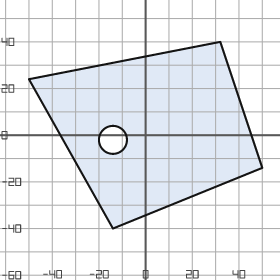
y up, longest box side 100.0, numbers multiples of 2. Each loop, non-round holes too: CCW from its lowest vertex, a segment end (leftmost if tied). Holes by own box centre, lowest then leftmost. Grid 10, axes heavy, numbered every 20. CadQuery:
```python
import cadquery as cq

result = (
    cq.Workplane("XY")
    .moveTo(-14.0, -40.0)
    .lineTo(50.0, -14.0)
    .lineTo(32.0, 40.0)
    .lineTo(-50.0, 24.0)
    .close()
    .moveTo(-14.0, -2.0)
    .circle(6.0)
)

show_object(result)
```